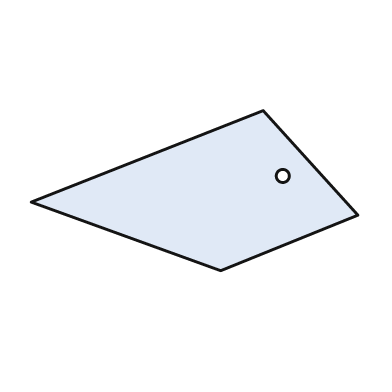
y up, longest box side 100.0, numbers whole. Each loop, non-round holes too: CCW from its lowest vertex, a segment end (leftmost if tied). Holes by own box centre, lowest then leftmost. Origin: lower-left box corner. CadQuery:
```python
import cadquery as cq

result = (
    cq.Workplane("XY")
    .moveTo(58.0, 0.0)
    .lineTo(100.0, 17.0)
    .lineTo(71.0, 49.0)
    .lineTo(0.0, 21.0)
    .close()
    .moveTo(77.0, 29.0)
    .circle(2.0)
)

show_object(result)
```